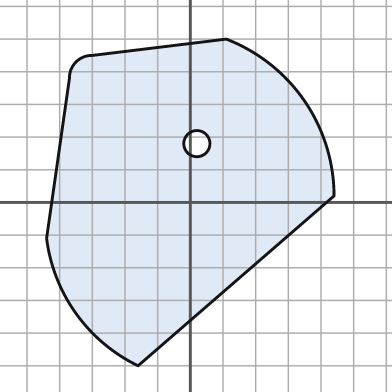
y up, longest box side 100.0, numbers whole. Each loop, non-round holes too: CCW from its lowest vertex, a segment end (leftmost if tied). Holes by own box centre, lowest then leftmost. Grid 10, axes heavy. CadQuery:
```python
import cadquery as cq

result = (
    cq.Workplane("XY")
    .moveTo(-16.0, -50.0)
    .lineTo(44.0, 2.0)
    .threePointArc((35.0, 31.0), (11.0, 50.0))
    .lineTo(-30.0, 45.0)
    .threePointArc((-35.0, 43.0), (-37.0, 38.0))
    .lineTo(-44.0, -11.0)
    .threePointArc((-35.0, -34.0), (-16.0, -50.0))
    .close()
    .moveTo(2.0, 18.0)
    .circle(4.0)
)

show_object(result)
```